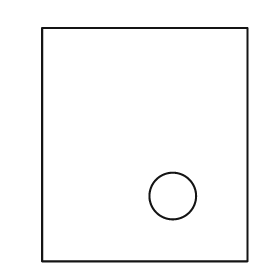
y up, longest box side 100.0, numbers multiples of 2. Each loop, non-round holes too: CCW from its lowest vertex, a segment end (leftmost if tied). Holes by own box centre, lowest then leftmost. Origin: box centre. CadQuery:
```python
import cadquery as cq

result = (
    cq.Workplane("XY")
    .moveTo(-44.0, -50.0)
    .lineTo(44.0, -50.0)
    .lineTo(44.0, 50.0)
    .lineTo(-44.0, 50.0)
    .close()
    .moveTo(12.0, -22.0)
    .circle(10.0)
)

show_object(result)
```